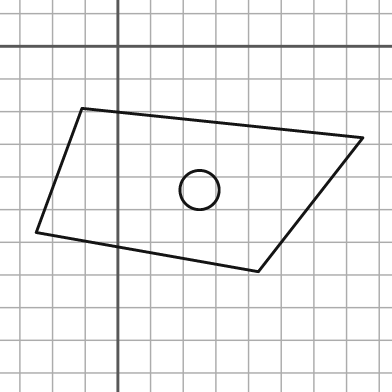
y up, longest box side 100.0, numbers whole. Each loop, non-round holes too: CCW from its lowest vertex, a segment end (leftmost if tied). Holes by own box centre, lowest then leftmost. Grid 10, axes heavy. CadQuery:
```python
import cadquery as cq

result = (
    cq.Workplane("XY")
    .moveTo(43.0, -69.0)
    .lineTo(75.0, -28.0)
    .lineTo(-11.0, -19.0)
    .lineTo(-25.0, -57.0)
    .close()
    .moveTo(25.0, -44.0)
    .circle(6.0)
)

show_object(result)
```